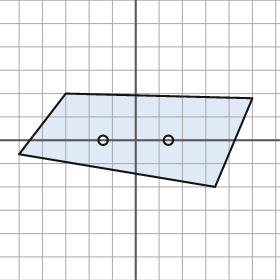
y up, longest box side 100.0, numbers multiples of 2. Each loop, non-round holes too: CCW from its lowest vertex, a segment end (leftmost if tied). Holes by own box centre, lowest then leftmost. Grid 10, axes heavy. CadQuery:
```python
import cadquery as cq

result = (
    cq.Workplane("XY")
    .moveTo(34.0, -20.0)
    .lineTo(50.0, 18.0)
    .lineTo(-30.0, 20.0)
    .lineTo(-50.0, -6.0)
    .close()
    .moveTo(-14.0, 0.0)
    .circle(2.0)
    .moveTo(14.0, 0.0)
    .circle(2.0)
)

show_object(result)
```